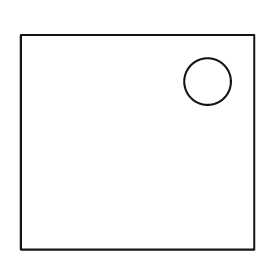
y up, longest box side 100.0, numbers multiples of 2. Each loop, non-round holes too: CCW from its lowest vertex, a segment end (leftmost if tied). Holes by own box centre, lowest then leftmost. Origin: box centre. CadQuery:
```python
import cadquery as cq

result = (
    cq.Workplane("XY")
    .moveTo(-50.0, -46.0)
    .lineTo(50.0, -46.0)
    .lineTo(50.0, 46.0)
    .lineTo(-50.0, 46.0)
    .close()
    .moveTo(30.0, 26.0)
    .circle(10.0)
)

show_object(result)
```